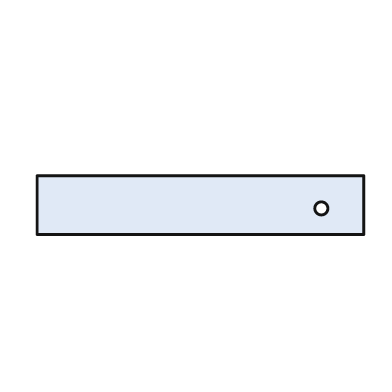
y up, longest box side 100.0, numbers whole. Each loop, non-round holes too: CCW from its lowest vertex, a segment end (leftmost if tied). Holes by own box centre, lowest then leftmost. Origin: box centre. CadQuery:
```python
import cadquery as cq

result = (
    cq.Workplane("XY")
    .moveTo(-50.0, -9.0)
    .lineTo(50.0, -9.0)
    .lineTo(50.0, 9.0)
    .lineTo(-50.0, 9.0)
    .close()
    .moveTo(37.0, -1.0)
    .circle(2.0)
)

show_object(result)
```